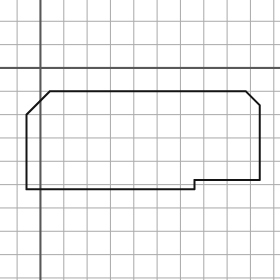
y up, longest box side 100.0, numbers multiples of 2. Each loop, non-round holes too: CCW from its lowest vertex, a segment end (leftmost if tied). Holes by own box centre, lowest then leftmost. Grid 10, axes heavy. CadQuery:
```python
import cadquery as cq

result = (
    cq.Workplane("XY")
    .moveTo(-6.0, -52.0)
    .lineTo(66.0, -52.0)
    .lineTo(66.0, -48.0)
    .lineTo(94.0, -48.0)
    .lineTo(94.0, -16.0)
    .lineTo(88.0, -10.0)
    .lineTo(4.0, -10.0)
    .lineTo(-6.0, -20.0)
    .close()
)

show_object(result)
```